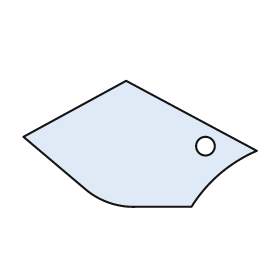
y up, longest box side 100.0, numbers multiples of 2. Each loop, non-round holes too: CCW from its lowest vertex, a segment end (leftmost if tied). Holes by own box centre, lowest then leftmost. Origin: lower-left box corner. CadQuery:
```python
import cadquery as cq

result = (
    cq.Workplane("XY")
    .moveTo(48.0, 0.0)
    .lineTo(72.0, 0.0)
    .threePointArc((84.0, 14.0), (100.0, 24.0))
    .lineTo(44.0, 54.0)
    .lineTo(0.0, 30.0)
    .lineTo(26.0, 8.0)
    .threePointArc((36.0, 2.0), (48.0, 0.0))
    .close()
    .moveTo(78.0, 26.0)
    .circle(4.0)
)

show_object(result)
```